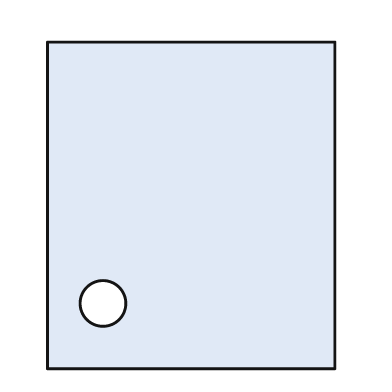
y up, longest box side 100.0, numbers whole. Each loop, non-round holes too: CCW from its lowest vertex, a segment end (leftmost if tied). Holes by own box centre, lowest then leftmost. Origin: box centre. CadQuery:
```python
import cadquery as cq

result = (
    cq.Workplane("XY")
    .moveTo(-44.0, -50.0)
    .lineTo(44.0, -50.0)
    .lineTo(44.0, 50.0)
    .lineTo(-44.0, 50.0)
    .close()
    .moveTo(-27.0, -30.0)
    .circle(7.0)
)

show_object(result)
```